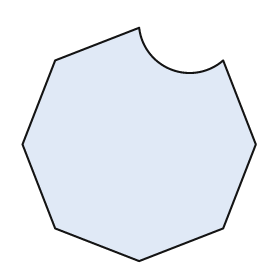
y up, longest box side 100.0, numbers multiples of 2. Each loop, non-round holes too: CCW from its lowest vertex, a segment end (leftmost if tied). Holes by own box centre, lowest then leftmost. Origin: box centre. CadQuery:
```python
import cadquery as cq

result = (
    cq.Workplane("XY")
    .moveTo(0.0, -50.0)
    .lineTo(36.0, -36.0)
    .lineTo(50.0, 0.0)
    .lineTo(36.0, 36.0)
    .threePointArc((14.0, 32.0), (0.0, 50.0))
    .lineTo(-36.0, 36.0)
    .lineTo(-50.0, 0.0)
    .lineTo(-36.0, -36.0)
    .close()
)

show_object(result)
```